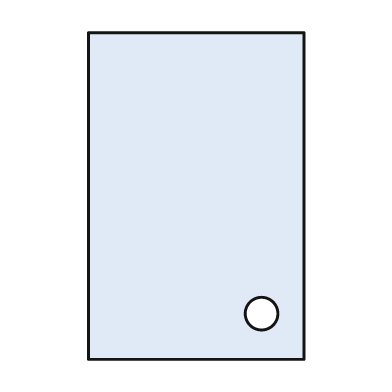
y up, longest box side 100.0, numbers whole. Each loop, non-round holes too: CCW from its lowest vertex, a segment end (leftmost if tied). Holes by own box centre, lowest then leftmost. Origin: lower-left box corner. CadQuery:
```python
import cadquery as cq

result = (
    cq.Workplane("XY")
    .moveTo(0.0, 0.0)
    .lineTo(66.0, 0.0)
    .lineTo(66.0, 100.0)
    .lineTo(0.0, 100.0)
    .close()
    .moveTo(53.0, 14.0)
    .circle(5.0)
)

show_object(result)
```